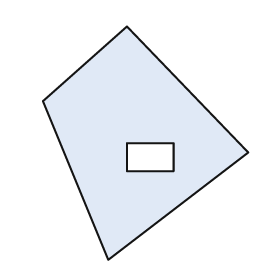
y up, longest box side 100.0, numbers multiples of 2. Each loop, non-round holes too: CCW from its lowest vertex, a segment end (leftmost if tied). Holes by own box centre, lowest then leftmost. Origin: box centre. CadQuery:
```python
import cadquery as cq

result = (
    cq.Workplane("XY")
    .moveTo(-16.0, -50.0)
    .lineTo(44.0, -4.0)
    .lineTo(-8.0, 50.0)
    .lineTo(-44.0, 18.0)
    .close()
    .moveTo(-8.0, -12.0)
    .lineTo(12.0, -12.0)
    .lineTo(12.0, 0.0)
    .lineTo(-8.0, 0.0)
    .close()
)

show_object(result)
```